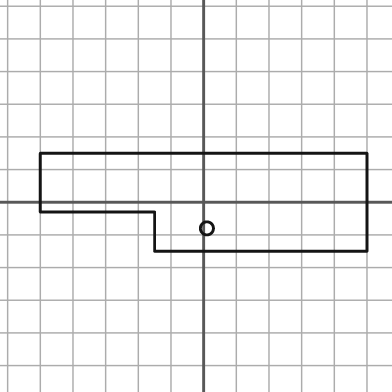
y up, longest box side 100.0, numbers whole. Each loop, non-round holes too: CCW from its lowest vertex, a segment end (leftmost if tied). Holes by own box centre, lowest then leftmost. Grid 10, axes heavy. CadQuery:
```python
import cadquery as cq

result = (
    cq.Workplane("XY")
    .moveTo(-15.0, -15.0)
    .lineTo(50.0, -15.0)
    .lineTo(50.0, 15.0)
    .lineTo(-50.0, 15.0)
    .lineTo(-50.0, -3.0)
    .lineTo(-15.0, -3.0)
    .close()
    .moveTo(1.0, -8.0)
    .circle(2.0)
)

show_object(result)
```